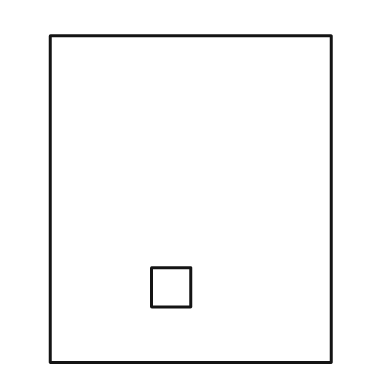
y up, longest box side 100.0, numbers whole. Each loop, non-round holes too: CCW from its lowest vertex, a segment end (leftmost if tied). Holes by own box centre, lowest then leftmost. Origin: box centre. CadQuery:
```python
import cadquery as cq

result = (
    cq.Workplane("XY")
    .moveTo(-43.0, -50.0)
    .lineTo(43.0, -50.0)
    .lineTo(43.0, 50.0)
    .lineTo(-43.0, 50.0)
    .close()
    .moveTo(-12.0, -33.0)
    .lineTo(0.0, -33.0)
    .lineTo(0.0, -21.0)
    .lineTo(-12.0, -21.0)
    .close()
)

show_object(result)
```